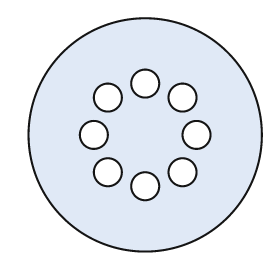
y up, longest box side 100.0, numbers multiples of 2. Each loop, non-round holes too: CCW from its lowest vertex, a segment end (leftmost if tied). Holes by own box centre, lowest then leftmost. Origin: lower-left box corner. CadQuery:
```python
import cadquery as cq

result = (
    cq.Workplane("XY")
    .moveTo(50.0, 50.0)
    .circle(50.0)
    .moveTo(50.0, 28.0)
    .circle(6.0)
    .moveTo(34.0, 34.0)
    .circle(6.0)
    .moveTo(66.0, 34.0)
    .circle(6.0)
    .moveTo(28.0, 50.0)
    .circle(6.0)
    .moveTo(72.0, 50.0)
    .circle(6.0)
    .moveTo(34.0, 66.0)
    .circle(6.0)
    .moveTo(66.0, 66.0)
    .circle(6.0)
    .moveTo(50.0, 72.0)
    .circle(6.0)
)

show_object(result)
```